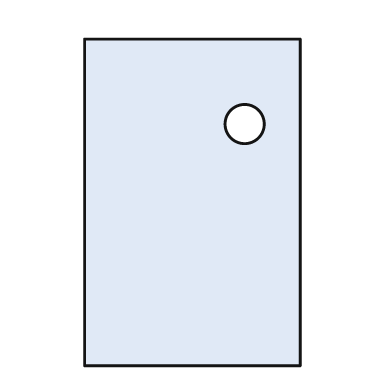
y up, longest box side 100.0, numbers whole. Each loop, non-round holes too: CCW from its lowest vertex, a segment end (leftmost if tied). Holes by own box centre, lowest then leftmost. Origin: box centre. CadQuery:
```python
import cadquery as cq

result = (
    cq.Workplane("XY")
    .moveTo(-33.0, -50.0)
    .lineTo(33.0, -50.0)
    .lineTo(33.0, 50.0)
    .lineTo(-33.0, 50.0)
    .close()
    .moveTo(16.0, 24.0)
    .circle(6.0)
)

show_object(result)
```